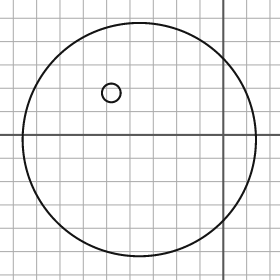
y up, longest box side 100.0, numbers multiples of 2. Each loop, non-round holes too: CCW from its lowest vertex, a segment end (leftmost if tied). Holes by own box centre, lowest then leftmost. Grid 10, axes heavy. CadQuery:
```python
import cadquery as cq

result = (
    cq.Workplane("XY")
    .moveTo(-36.0, -2.0)
    .circle(50.0)
    .moveTo(-48.0, 18.0)
    .circle(4.0)
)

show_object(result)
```